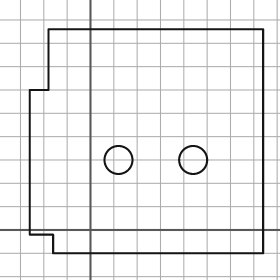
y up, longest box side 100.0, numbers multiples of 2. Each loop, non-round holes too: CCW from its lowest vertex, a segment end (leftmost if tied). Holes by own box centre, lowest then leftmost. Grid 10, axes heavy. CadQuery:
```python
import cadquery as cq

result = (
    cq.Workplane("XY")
    .moveTo(-16.0, -10.0)
    .lineTo(74.0, -10.0)
    .lineTo(74.0, 86.0)
    .lineTo(-18.0, 86.0)
    .lineTo(-18.0, 60.0)
    .lineTo(-26.0, 60.0)
    .lineTo(-26.0, -2.0)
    .lineTo(-16.0, -2.0)
    .close()
    .moveTo(12.0, 30.0)
    .circle(6.0)
    .moveTo(44.0, 30.0)
    .circle(6.0)
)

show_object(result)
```